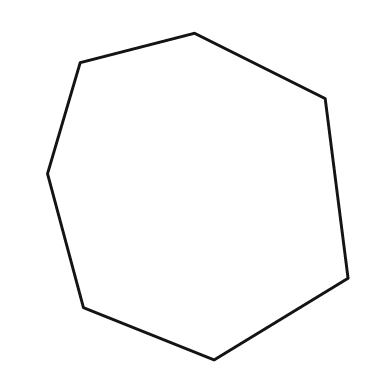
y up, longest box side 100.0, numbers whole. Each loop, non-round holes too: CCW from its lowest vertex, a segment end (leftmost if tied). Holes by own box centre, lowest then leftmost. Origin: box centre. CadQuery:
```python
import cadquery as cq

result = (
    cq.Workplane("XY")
    .moveTo(5.0, -50.0)
    .lineTo(46.0, -25.0)
    .lineTo(39.0, 30.0)
    .lineTo(-1.0, 50.0)
    .lineTo(-36.0, 41.0)
    .lineTo(-46.0, 7.0)
    .lineTo(-35.0, -34.0)
    .close()
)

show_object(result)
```